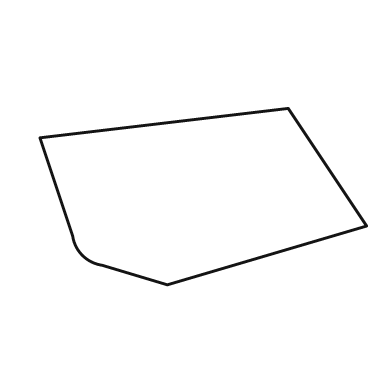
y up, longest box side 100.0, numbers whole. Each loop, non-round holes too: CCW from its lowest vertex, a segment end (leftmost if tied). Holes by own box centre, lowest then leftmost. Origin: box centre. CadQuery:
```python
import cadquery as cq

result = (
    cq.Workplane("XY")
    .moveTo(-11.0, -27.0)
    .lineTo(50.0, -9.0)
    .lineTo(26.0, 27.0)
    .lineTo(-50.0, 18.0)
    .lineTo(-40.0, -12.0)
    .threePointArc((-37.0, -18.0), (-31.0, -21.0))
    .close()
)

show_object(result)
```